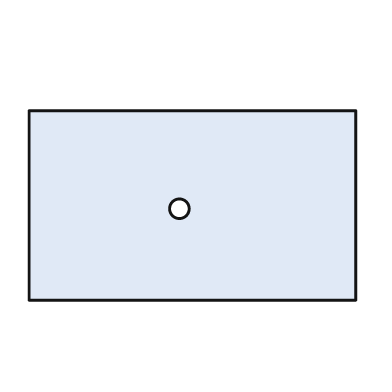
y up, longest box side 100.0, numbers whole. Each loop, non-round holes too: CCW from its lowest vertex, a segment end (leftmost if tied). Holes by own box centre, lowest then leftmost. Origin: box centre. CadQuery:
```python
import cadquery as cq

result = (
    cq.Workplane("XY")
    .moveTo(-50.0, -29.0)
    .lineTo(50.0, -29.0)
    .lineTo(50.0, 29.0)
    .lineTo(-50.0, 29.0)
    .close()
    .moveTo(-4.0, -1.0)
    .circle(3.0)
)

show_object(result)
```